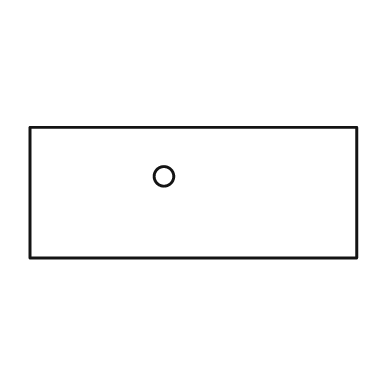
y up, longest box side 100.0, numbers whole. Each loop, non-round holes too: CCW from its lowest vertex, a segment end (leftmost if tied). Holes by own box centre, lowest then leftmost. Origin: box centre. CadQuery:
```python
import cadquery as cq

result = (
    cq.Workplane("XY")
    .moveTo(-50.0, -20.0)
    .lineTo(50.0, -20.0)
    .lineTo(50.0, 20.0)
    .lineTo(-50.0, 20.0)
    .close()
    .moveTo(-9.0, 5.0)
    .circle(3.0)
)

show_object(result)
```